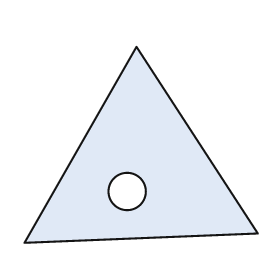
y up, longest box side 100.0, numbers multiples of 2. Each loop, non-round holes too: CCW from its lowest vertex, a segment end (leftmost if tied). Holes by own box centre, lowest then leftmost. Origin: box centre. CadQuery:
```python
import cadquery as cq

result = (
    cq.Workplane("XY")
    .moveTo(-50.0, -42.0)
    .lineTo(50.0, -38.0)
    .lineTo(-2.0, 42.0)
    .close()
    .moveTo(-6.0, -20.0)
    .circle(8.0)
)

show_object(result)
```